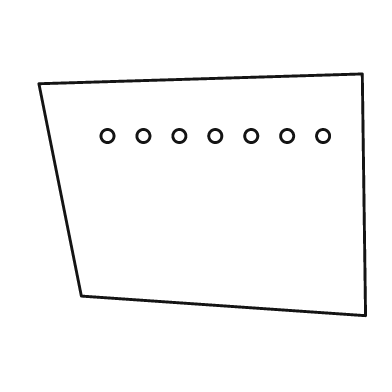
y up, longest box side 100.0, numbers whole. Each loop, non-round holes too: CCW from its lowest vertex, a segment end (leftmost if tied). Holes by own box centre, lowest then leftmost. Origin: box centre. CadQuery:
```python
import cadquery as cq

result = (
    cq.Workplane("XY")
    .moveTo(50.0, -37.0)
    .lineTo(49.0, 37.0)
    .lineTo(-50.0, 34.0)
    .lineTo(-37.0, -31.0)
    .close()
    .moveTo(-29.0, 18.0)
    .circle(2.0)
    .moveTo(-18.0, 18.0)
    .circle(2.0)
    .moveTo(-7.0, 18.0)
    .circle(2.0)
    .moveTo(4.0, 18.0)
    .circle(2.0)
    .moveTo(15.0, 18.0)
    .circle(2.0)
    .moveTo(26.0, 18.0)
    .circle(2.0)
    .moveTo(37.0, 18.0)
    .circle(2.0)
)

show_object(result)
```